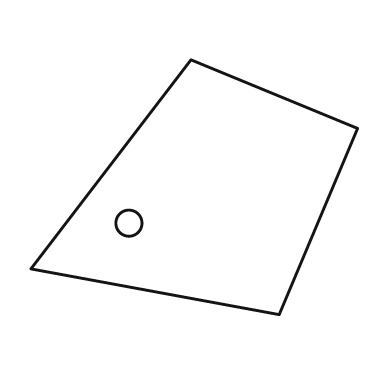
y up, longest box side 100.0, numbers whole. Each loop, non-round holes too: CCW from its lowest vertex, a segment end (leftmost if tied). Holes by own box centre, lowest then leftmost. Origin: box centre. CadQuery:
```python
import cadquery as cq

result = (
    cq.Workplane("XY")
    .moveTo(26.0, -39.0)
    .lineTo(50.0, 18.0)
    .lineTo(-1.0, 39.0)
    .lineTo(-50.0, -25.0)
    .close()
    .moveTo(-20.0, -11.0)
    .circle(4.0)
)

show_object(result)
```